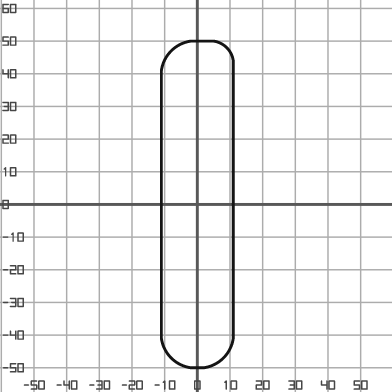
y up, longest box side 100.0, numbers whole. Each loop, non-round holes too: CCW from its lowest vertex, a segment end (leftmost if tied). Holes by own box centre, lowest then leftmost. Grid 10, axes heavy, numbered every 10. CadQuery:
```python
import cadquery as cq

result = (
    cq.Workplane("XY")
    .moveTo(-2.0, -50.0)
    .lineTo(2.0, -50.0)
    .threePointArc((8.0, -47.0), (11.0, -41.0))
    .lineTo(11.0, 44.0)
    .threePointArc((9.0, 48.0), (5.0, 50.0))
    .lineTo(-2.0, 50.0)
    .threePointArc((-8.0, 47.0), (-11.0, 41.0))
    .lineTo(-11.0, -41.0)
    .threePointArc((-8.0, -47.0), (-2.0, -50.0))
    .close()
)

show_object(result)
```